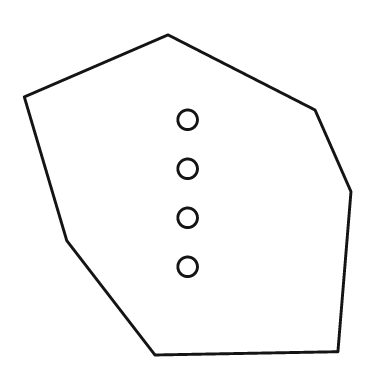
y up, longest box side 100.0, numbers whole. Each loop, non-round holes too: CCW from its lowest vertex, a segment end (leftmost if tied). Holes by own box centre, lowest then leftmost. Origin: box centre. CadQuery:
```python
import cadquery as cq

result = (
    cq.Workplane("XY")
    .moveTo(-10.0, -49.0)
    .lineTo(46.0, -48.0)
    .lineTo(50.0, 1.0)
    .lineTo(39.0, 26.0)
    .lineTo(-6.0, 49.0)
    .lineTo(-50.0, 30.0)
    .lineTo(-37.0, -14.0)
    .close()
    .moveTo(0.0, -22.0)
    .circle(3.0)
    .moveTo(0.0, -7.0)
    .circle(3.0)
    .moveTo(0.0, 8.0)
    .circle(3.0)
    .moveTo(0.0, 23.0)
    .circle(3.0)
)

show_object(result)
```